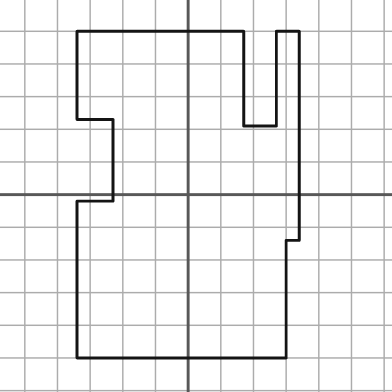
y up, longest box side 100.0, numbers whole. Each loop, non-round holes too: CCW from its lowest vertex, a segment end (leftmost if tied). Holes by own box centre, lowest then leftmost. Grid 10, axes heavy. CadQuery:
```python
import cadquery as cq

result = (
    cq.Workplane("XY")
    .moveTo(-34.0, -50.0)
    .lineTo(30.0, -50.0)
    .lineTo(30.0, -14.0)
    .lineTo(34.0, -14.0)
    .lineTo(34.0, 50.0)
    .lineTo(27.0, 50.0)
    .lineTo(27.0, 21.0)
    .lineTo(17.0, 21.0)
    .lineTo(17.0, 50.0)
    .lineTo(-34.0, 50.0)
    .lineTo(-34.0, 23.0)
    .lineTo(-23.0, 23.0)
    .lineTo(-23.0, -2.0)
    .lineTo(-34.0, -2.0)
    .close()
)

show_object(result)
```